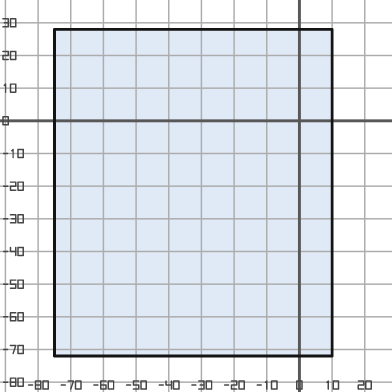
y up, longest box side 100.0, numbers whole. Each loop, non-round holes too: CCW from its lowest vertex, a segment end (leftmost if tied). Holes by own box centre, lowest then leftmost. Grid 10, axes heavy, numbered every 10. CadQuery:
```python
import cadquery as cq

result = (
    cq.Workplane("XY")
    .moveTo(-75.0, -72.0)
    .lineTo(10.0, -72.0)
    .lineTo(10.0, 28.0)
    .lineTo(-75.0, 28.0)
    .close()
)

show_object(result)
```